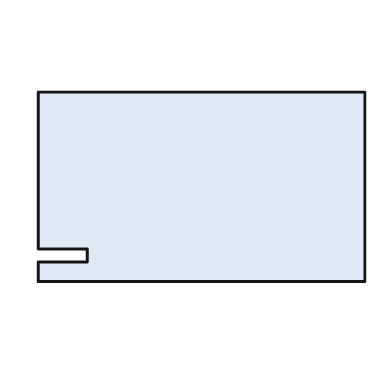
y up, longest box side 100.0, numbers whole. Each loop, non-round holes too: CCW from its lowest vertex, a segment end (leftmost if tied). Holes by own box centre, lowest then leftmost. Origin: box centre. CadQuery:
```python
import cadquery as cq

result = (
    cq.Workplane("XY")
    .moveTo(-50.0, -29.0)
    .lineTo(50.0, -29.0)
    .lineTo(50.0, 29.0)
    .lineTo(-50.0, 29.0)
    .lineTo(-50.0, -19.0)
    .lineTo(-35.0, -19.0)
    .lineTo(-35.0, -23.0)
    .lineTo(-50.0, -23.0)
    .close()
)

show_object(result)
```